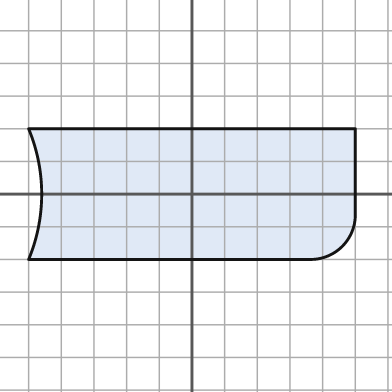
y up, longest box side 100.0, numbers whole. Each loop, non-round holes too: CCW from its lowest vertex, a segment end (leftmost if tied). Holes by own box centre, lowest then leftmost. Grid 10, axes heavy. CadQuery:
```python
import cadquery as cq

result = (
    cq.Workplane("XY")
    .moveTo(-50.0, -20.0)
    .lineTo(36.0, -20.0)
    .threePointArc((46.0, -16.0), (50.0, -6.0))
    .lineTo(50.0, 20.0)
    .lineTo(-50.0, 20.0)
    .threePointArc((-46.0, 0.0), (-50.0, -20.0))
    .close()
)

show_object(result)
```